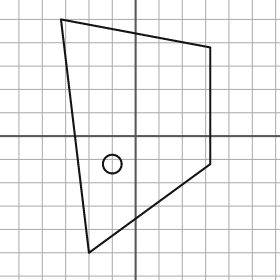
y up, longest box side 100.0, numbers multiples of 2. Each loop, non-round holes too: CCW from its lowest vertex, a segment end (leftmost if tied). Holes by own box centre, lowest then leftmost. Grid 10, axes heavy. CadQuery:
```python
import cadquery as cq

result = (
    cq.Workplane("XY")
    .moveTo(-20.0, -50.0)
    .lineTo(32.0, -12.0)
    .lineTo(32.0, 38.0)
    .lineTo(-32.0, 50.0)
    .close()
    .moveTo(-10.0, -12.0)
    .circle(4.0)
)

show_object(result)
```